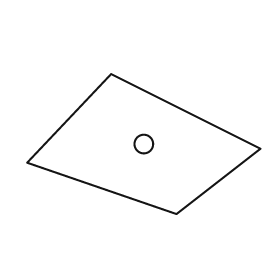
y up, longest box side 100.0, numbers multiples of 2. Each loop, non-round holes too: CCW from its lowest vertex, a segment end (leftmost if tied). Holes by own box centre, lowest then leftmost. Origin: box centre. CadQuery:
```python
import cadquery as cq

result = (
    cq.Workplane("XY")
    .moveTo(14.0, -30.0)
    .lineTo(50.0, -2.0)
    .lineTo(-14.0, 30.0)
    .lineTo(-50.0, -8.0)
    .close()
    .moveTo(0.0, 0.0)
    .circle(4.0)
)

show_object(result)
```